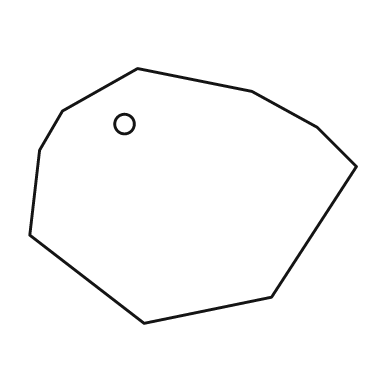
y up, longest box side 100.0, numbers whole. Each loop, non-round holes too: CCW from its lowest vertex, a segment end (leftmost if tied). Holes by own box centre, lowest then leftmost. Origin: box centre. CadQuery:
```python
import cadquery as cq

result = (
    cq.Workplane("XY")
    .moveTo(-15.0, -39.0)
    .lineTo(24.0, -31.0)
    .lineTo(50.0, 9.0)
    .lineTo(38.0, 21.0)
    .lineTo(18.0, 32.0)
    .lineTo(-17.0, 39.0)
    .lineTo(-40.0, 26.0)
    .lineTo(-47.0, 14.0)
    .lineTo(-50.0, -12.0)
    .close()
    .moveTo(-21.0, 22.0)
    .circle(3.0)
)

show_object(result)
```